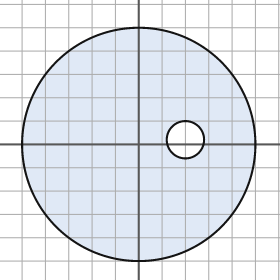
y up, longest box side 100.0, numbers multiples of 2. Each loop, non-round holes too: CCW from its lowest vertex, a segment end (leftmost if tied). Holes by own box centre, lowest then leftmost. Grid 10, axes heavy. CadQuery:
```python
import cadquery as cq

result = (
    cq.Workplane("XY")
    .moveTo(0.0, 0.0)
    .circle(50.0)
    .moveTo(20.0, 2.0)
    .circle(8.0)
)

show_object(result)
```